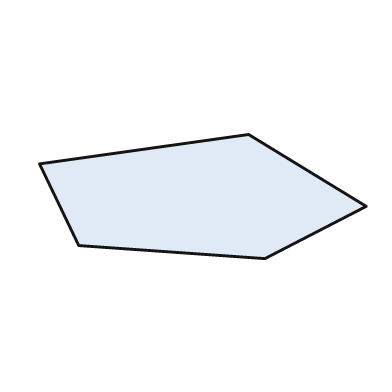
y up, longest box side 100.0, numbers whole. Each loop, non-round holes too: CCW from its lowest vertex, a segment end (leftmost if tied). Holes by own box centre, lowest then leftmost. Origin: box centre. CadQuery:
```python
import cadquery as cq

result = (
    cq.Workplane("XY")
    .moveTo(19.0, -19.0)
    .lineTo(50.0, -3.0)
    .lineTo(14.0, 19.0)
    .lineTo(-50.0, 10.0)
    .lineTo(-38.0, -15.0)
    .close()
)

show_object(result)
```